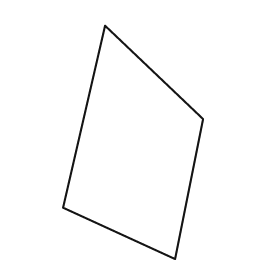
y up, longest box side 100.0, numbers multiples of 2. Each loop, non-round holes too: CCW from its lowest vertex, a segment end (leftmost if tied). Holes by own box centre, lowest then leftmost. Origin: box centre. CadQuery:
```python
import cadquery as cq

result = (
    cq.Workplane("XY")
    .moveTo(18.0, -50.0)
    .lineTo(30.0, 10.0)
    .lineTo(-12.0, 50.0)
    .lineTo(-30.0, -28.0)
    .close()
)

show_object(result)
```